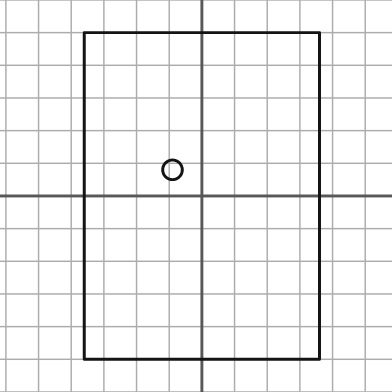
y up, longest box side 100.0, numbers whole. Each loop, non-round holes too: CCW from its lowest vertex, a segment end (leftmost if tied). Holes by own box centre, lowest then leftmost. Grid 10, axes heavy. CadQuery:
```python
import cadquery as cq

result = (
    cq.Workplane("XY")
    .moveTo(-36.0, -50.0)
    .lineTo(36.0, -50.0)
    .lineTo(36.0, 50.0)
    .lineTo(-36.0, 50.0)
    .close()
    .moveTo(-9.0, 8.0)
    .circle(3.0)
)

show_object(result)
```